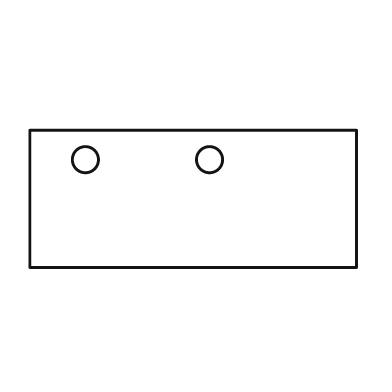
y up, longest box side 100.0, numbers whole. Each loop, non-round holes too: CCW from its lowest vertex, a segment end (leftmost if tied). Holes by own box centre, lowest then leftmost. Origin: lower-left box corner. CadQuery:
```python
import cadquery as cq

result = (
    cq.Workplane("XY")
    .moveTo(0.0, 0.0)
    .lineTo(100.0, 0.0)
    .lineTo(100.0, 42.0)
    .lineTo(0.0, 42.0)
    .close()
    .moveTo(17.0, 33.0)
    .circle(4.0)
    .moveTo(55.0, 33.0)
    .circle(4.0)
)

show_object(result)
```